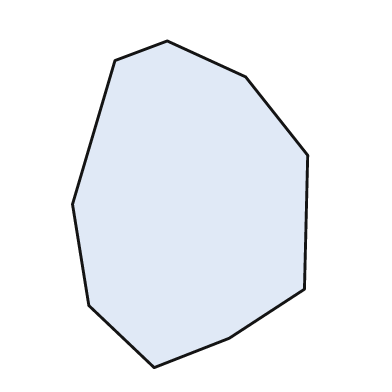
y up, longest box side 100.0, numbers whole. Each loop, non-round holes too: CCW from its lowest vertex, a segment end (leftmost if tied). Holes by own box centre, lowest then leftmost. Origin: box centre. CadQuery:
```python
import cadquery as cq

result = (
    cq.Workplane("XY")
    .moveTo(-11.0, -50.0)
    .lineTo(12.0, -41.0)
    .lineTo(35.0, -26.0)
    .lineTo(36.0, 15.0)
    .lineTo(17.0, 39.0)
    .lineTo(-7.0, 50.0)
    .lineTo(-23.0, 44.0)
    .lineTo(-36.0, 0.0)
    .lineTo(-31.0, -31.0)
    .close()
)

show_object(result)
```